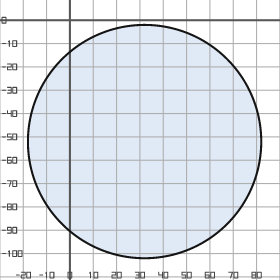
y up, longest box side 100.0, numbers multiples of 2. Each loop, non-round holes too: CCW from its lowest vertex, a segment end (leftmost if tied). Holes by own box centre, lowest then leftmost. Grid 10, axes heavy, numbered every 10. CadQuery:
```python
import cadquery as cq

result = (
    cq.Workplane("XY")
    .moveTo(32.0, -52.0)
    .circle(50.0)
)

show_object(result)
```